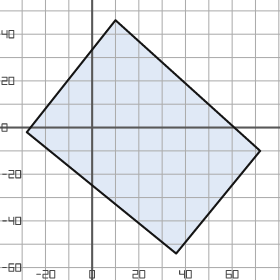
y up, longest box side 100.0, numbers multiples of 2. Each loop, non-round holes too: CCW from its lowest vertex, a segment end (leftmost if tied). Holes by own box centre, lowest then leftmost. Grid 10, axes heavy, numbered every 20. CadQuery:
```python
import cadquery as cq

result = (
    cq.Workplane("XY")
    .moveTo(36.0, -54.0)
    .lineTo(72.0, -10.0)
    .lineTo(10.0, 46.0)
    .lineTo(-28.0, -2.0)
    .close()
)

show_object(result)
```